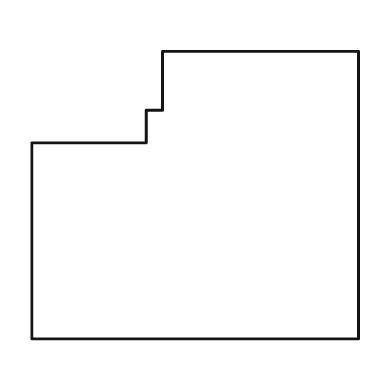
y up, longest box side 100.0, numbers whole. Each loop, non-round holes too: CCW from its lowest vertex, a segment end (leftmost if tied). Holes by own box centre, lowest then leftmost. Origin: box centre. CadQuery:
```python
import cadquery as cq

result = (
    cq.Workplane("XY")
    .moveTo(-50.0, -44.0)
    .lineTo(50.0, -44.0)
    .lineTo(50.0, 44.0)
    .lineTo(-10.0, 44.0)
    .lineTo(-10.0, 26.0)
    .lineTo(-15.0, 26.0)
    .lineTo(-15.0, 16.0)
    .lineTo(-50.0, 16.0)
    .close()
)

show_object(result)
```